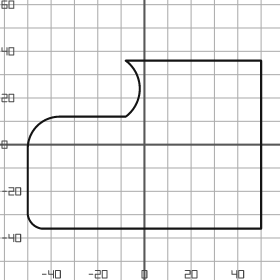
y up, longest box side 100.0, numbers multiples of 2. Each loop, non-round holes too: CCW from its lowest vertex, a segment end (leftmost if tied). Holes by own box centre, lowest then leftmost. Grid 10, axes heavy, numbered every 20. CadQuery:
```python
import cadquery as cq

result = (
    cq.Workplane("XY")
    .moveTo(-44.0, -36.0)
    .lineTo(50.0, -36.0)
    .lineTo(50.0, 36.0)
    .lineTo(-8.0, 36.0)
    .threePointArc((-2.0, 24.0), (-8.0, 12.0))
    .lineTo(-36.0, 12.0)
    .threePointArc((-46.0, 8.0), (-50.0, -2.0))
    .lineTo(-50.0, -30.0)
    .threePointArc((-48.0, -34.0), (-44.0, -36.0))
    .close()
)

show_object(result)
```